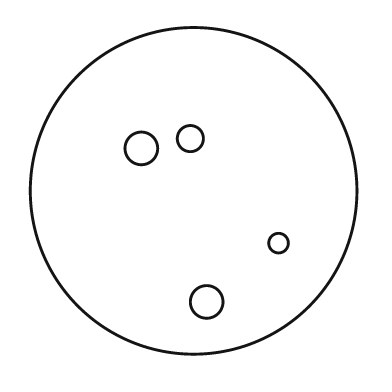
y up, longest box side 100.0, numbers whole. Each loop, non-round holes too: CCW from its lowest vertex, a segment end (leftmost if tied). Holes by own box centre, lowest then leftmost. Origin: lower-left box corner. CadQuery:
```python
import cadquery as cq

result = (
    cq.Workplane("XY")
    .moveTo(50.0, 50.0)
    .circle(50.0)
    .moveTo(54.0, 16.0)
    .circle(5.0)
    .moveTo(76.0, 34.0)
    .circle(3.0)
    .moveTo(34.0, 63.0)
    .circle(5.0)
    .moveTo(49.0, 66.0)
    .circle(4.0)
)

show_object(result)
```